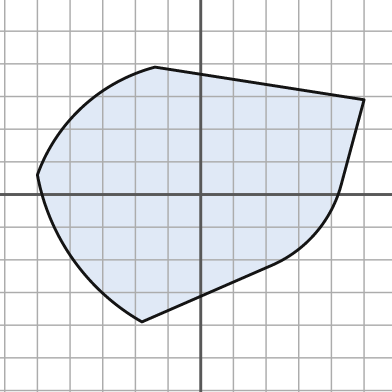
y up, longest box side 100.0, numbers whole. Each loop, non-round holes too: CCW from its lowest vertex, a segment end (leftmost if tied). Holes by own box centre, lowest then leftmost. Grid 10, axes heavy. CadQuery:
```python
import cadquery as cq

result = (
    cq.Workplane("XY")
    .moveTo(-18.0, -39.0)
    .lineTo(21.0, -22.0)
    .threePointArc((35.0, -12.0), (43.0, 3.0))
    .lineTo(50.0, 29.0)
    .lineTo(-14.0, 39.0)
    .threePointArc((-36.0, 27.0), (-50.0, 6.0))
    .threePointArc((-39.0, -20.0), (-18.0, -39.0))
    .close()
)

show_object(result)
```